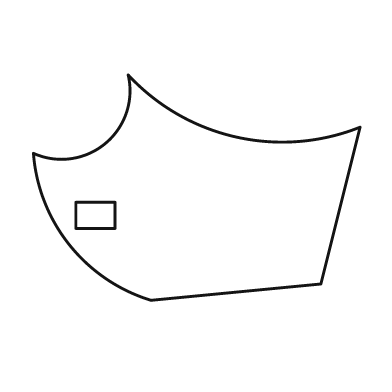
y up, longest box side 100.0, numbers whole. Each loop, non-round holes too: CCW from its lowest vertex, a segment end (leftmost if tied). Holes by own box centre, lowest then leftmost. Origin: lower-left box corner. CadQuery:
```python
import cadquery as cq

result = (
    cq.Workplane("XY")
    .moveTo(36.0, 0.0)
    .lineTo(88.0, 5.0)
    .lineTo(100.0, 53.0)
    .threePointArc((62.0, 50.0), (29.0, 69.0))
    .threePointArc((22.0, 48.0), (0.0, 45.0))
    .threePointArc((11.0, 17.0), (36.0, 0.0))
    .close()
    .moveTo(13.0, 22.0)
    .lineTo(25.0, 22.0)
    .lineTo(25.0, 30.0)
    .lineTo(13.0, 30.0)
    .close()
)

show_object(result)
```